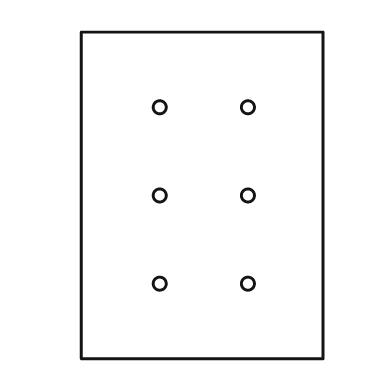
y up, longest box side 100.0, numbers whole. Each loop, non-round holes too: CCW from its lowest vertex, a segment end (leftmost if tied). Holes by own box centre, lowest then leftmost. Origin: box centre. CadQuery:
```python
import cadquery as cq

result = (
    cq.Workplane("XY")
    .moveTo(-37.0, -50.0)
    .lineTo(37.0, -50.0)
    .lineTo(37.0, 50.0)
    .lineTo(-37.0, 50.0)
    .close()
    .moveTo(-13.0, -27.0)
    .circle(2.0)
    .moveTo(14.0, -27.0)
    .circle(2.0)
    .moveTo(-13.0, 0.0)
    .circle(2.0)
    .moveTo(14.0, 0.0)
    .circle(2.0)
    .moveTo(-13.0, 27.0)
    .circle(2.0)
    .moveTo(14.0, 27.0)
    .circle(2.0)
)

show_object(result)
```